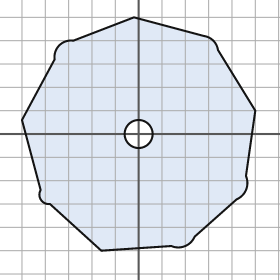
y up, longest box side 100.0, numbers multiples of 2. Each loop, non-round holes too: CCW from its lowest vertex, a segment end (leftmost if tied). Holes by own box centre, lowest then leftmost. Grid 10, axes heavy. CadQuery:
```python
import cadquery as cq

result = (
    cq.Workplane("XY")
    .moveTo(-16.0, -50.0)
    .lineTo(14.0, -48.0)
    .threePointArc((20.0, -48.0), (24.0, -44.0))
    .lineTo(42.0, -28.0)
    .threePointArc((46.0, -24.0), (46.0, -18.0))
    .lineTo(50.0, 10.0)
    .lineTo(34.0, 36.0)
    .threePointArc((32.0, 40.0), (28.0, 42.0))
    .lineTo(-2.0, 50.0)
    .lineTo(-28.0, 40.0)
    .threePointArc((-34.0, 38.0), (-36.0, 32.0))
    .lineTo(-50.0, 6.0)
    .lineTo(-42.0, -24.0)
    .threePointArc((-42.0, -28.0), (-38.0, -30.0))
    .close()
    .moveTo(0.0, 0.0)
    .circle(6.0)
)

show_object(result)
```